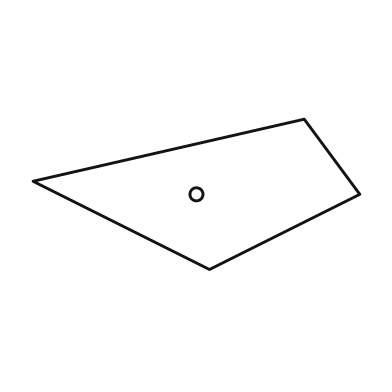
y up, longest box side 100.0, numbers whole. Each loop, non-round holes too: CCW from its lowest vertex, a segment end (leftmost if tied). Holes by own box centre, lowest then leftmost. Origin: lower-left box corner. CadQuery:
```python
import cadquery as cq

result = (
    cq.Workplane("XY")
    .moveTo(54.0, 0.0)
    .lineTo(100.0, 23.0)
    .lineTo(83.0, 46.0)
    .lineTo(0.0, 27.0)
    .close()
    .moveTo(50.0, 23.0)
    .circle(2.0)
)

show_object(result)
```